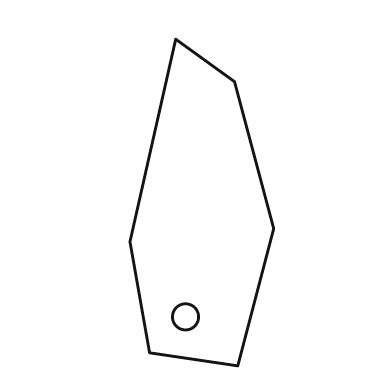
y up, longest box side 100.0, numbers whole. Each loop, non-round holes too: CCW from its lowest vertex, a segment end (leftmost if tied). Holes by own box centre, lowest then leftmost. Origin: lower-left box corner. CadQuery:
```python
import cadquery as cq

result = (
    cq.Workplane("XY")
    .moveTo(33.0, 0.0)
    .lineTo(44.0, 42.0)
    .lineTo(32.0, 87.0)
    .lineTo(14.0, 100.0)
    .lineTo(0.0, 38.0)
    .lineTo(6.0, 4.0)
    .close()
    .moveTo(17.0, 15.0)
    .circle(4.0)
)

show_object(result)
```